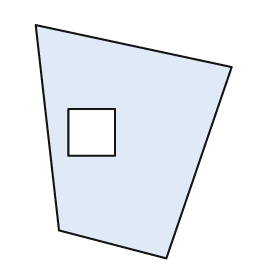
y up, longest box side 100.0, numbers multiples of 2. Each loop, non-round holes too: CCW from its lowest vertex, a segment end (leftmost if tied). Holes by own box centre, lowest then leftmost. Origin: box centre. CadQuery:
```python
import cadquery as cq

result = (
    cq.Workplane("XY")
    .moveTo(14.0, -50.0)
    .lineTo(42.0, 32.0)
    .lineTo(-42.0, 50.0)
    .lineTo(-32.0, -38.0)
    .close()
    .moveTo(-28.0, -6.0)
    .lineTo(-8.0, -6.0)
    .lineTo(-8.0, 14.0)
    .lineTo(-28.0, 14.0)
    .close()
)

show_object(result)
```